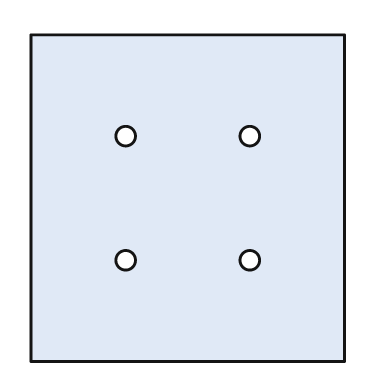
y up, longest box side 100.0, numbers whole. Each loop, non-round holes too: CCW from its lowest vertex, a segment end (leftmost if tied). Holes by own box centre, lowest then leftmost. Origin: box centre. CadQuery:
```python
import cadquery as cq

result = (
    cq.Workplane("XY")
    .moveTo(-48.0, -50.0)
    .lineTo(48.0, -50.0)
    .lineTo(48.0, 50.0)
    .lineTo(-48.0, 50.0)
    .close()
    .moveTo(-19.0, -19.0)
    .circle(3.0)
    .moveTo(19.0, -19.0)
    .circle(3.0)
    .moveTo(-19.0, 19.0)
    .circle(3.0)
    .moveTo(19.0, 19.0)
    .circle(3.0)
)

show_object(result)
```